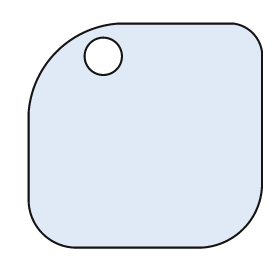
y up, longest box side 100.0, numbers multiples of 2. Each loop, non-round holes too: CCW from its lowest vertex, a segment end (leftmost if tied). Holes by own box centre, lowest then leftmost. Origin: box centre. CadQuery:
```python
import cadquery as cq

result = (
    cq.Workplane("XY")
    .moveTo(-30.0, -48.0)
    .lineTo(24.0, -48.0)
    .threePointArc((42.0, -40.0), (50.0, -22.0))
    .lineTo(50.0, 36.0)
    .threePointArc((46.0, 44.0), (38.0, 48.0))
    .lineTo(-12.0, 48.0)
    .threePointArc((-38.0, 36.0), (-50.0, 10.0))
    .lineTo(-50.0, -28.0)
    .threePointArc((-44.0, -42.0), (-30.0, -48.0))
    .close()
    .moveTo(-18.0, 34.0)
    .circle(8.0)
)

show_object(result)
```